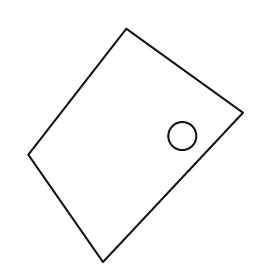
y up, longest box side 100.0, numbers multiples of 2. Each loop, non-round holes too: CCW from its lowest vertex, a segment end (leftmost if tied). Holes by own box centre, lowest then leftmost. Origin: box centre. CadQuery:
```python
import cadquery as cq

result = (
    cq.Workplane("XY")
    .moveTo(-14.0, -50.0)
    .lineTo(46.0, 14.0)
    .lineTo(-4.0, 50.0)
    .lineTo(-46.0, -4.0)
    .close()
    .moveTo(20.0, 4.0)
    .circle(6.0)
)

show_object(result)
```